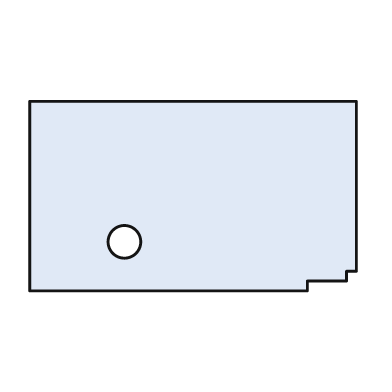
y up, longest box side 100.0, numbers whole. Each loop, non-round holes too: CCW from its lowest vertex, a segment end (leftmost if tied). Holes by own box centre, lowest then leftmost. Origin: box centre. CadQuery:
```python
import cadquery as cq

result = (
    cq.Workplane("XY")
    .moveTo(-50.0, -29.0)
    .lineTo(35.0, -29.0)
    .lineTo(35.0, -26.0)
    .lineTo(47.0, -26.0)
    .lineTo(47.0, -23.0)
    .lineTo(50.0, -23.0)
    .lineTo(50.0, 29.0)
    .lineTo(-50.0, 29.0)
    .close()
    .moveTo(-21.0, -14.0)
    .circle(5.0)
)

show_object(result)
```